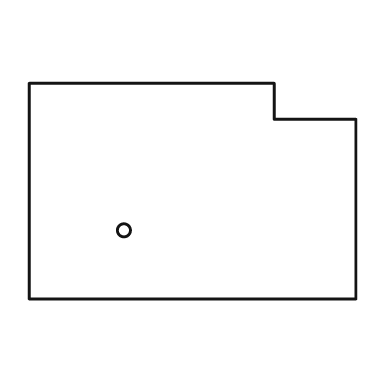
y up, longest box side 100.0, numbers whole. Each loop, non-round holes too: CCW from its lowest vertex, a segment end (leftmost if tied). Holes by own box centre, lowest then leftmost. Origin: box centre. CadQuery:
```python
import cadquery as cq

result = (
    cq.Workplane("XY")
    .moveTo(-50.0, -33.0)
    .lineTo(50.0, -33.0)
    .lineTo(50.0, 22.0)
    .lineTo(25.0, 22.0)
    .lineTo(25.0, 33.0)
    .lineTo(-50.0, 33.0)
    .close()
    .moveTo(-21.0, -12.0)
    .circle(2.0)
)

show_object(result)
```